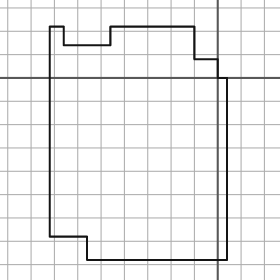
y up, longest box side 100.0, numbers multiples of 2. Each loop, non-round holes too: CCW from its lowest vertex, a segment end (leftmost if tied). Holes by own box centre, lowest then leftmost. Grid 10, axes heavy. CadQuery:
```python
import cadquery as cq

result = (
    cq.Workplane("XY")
    .moveTo(-56.0, -78.0)
    .lineTo(4.0, -78.0)
    .lineTo(4.0, 0.0)
    .lineTo(0.0, 0.0)
    .lineTo(0.0, 8.0)
    .lineTo(-10.0, 8.0)
    .lineTo(-10.0, 22.0)
    .lineTo(-46.0, 22.0)
    .lineTo(-46.0, 14.0)
    .lineTo(-66.0, 14.0)
    .lineTo(-66.0, 22.0)
    .lineTo(-72.0, 22.0)
    .lineTo(-72.0, -68.0)
    .lineTo(-56.0, -68.0)
    .close()
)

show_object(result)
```